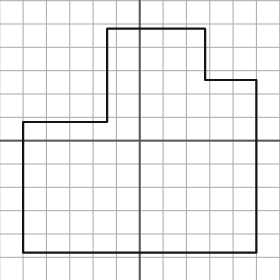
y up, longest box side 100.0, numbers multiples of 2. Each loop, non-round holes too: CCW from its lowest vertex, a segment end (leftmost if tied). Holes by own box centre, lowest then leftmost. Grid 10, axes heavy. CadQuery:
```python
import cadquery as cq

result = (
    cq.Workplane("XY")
    .moveTo(-50.0, -48.0)
    .lineTo(50.0, -48.0)
    .lineTo(50.0, 26.0)
    .lineTo(28.0, 26.0)
    .lineTo(28.0, 48.0)
    .lineTo(-14.0, 48.0)
    .lineTo(-14.0, 8.0)
    .lineTo(-50.0, 8.0)
    .close()
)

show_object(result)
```